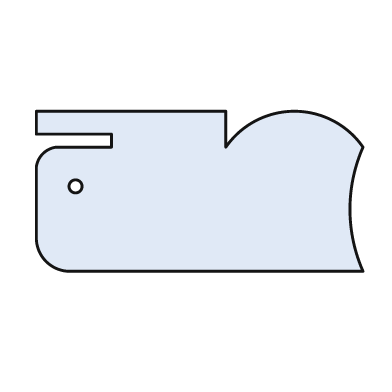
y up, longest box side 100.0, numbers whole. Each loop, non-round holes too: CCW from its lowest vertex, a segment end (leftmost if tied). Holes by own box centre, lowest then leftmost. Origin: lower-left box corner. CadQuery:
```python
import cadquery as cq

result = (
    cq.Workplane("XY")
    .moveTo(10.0, 0.0)
    .lineTo(100.0, 0.0)
    .threePointArc((96.0, 19.0), (100.0, 38.0))
    .threePointArc((79.0, 49.0), (58.0, 38.0))
    .lineTo(58.0, 49.0)
    .lineTo(0.0, 49.0)
    .lineTo(0.0, 42.0)
    .lineTo(23.0, 42.0)
    .lineTo(23.0, 38.0)
    .lineTo(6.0, 38.0)
    .threePointArc((2.0, 36.0), (0.0, 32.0))
    .lineTo(0.0, 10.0)
    .threePointArc((3.0, 3.0), (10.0, 0.0))
    .close()
    .moveTo(12.0, 26.0)
    .circle(2.0)
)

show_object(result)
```